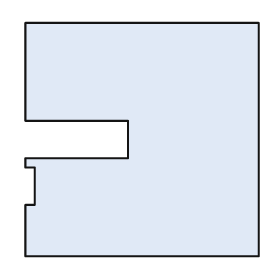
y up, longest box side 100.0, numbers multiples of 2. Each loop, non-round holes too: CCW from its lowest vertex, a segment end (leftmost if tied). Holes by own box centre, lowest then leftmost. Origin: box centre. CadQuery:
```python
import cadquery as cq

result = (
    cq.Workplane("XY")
    .moveTo(-50.0, -50.0)
    .lineTo(50.0, -50.0)
    .lineTo(50.0, 50.0)
    .lineTo(-50.0, 50.0)
    .lineTo(-50.0, 8.0)
    .lineTo(-6.0, 8.0)
    .lineTo(-6.0, -8.0)
    .lineTo(-50.0, -8.0)
    .lineTo(-50.0, -12.0)
    .lineTo(-46.0, -12.0)
    .lineTo(-46.0, -28.0)
    .lineTo(-50.0, -28.0)
    .close()
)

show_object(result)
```